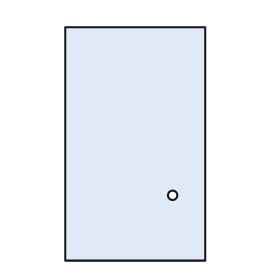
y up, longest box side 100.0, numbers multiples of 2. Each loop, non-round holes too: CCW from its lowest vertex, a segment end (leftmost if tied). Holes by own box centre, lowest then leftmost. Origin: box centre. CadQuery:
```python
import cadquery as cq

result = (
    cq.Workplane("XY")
    .moveTo(-30.0, -50.0)
    .lineTo(30.0, -50.0)
    .lineTo(30.0, 50.0)
    .lineTo(-30.0, 50.0)
    .close()
    .moveTo(16.0, -22.0)
    .circle(2.0)
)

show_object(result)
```